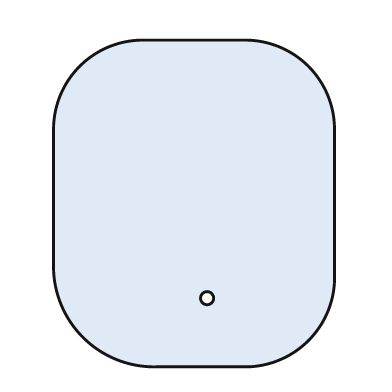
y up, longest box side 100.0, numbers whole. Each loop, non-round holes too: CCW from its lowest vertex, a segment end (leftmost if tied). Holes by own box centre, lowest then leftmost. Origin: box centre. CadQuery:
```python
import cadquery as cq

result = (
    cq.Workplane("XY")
    .moveTo(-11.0, -50.0)
    .lineTo(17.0, -50.0)
    .threePointArc((35.0, -42.0), (43.0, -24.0))
    .lineTo(43.0, 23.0)
    .threePointArc((35.0, 42.0), (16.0, 50.0))
    .lineTo(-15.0, 50.0)
    .threePointArc((-35.0, 42.0), (-43.0, 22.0))
    .lineTo(-43.0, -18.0)
    .threePointArc((-34.0, -41.0), (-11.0, -50.0))
    .close()
    .moveTo(4.0, -29.0)
    .circle(2.0)
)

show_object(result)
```